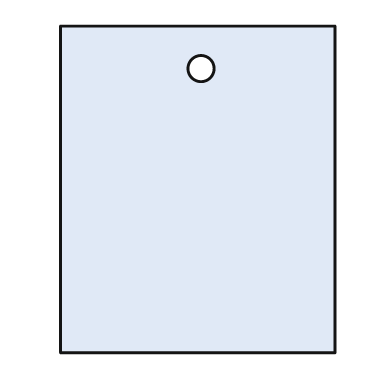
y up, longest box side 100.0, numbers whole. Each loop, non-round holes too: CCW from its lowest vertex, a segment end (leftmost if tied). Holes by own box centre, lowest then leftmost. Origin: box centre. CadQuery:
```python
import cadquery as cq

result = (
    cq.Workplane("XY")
    .moveTo(-42.0, -50.0)
    .lineTo(42.0, -50.0)
    .lineTo(42.0, 50.0)
    .lineTo(-42.0, 50.0)
    .close()
    .moveTo(1.0, 37.0)
    .circle(4.0)
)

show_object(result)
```